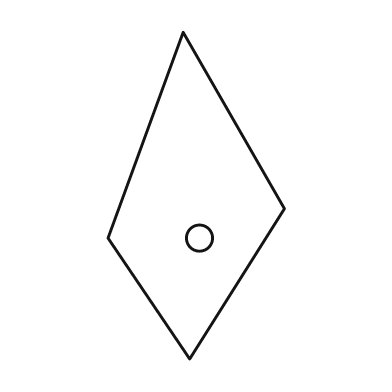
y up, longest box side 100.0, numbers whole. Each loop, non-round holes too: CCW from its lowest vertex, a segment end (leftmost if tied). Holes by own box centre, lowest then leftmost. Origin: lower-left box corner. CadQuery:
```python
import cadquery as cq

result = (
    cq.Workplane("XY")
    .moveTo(25.0, 0.0)
    .lineTo(54.0, 46.0)
    .lineTo(23.0, 100.0)
    .lineTo(0.0, 37.0)
    .close()
    .moveTo(28.0, 37.0)
    .circle(4.0)
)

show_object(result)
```